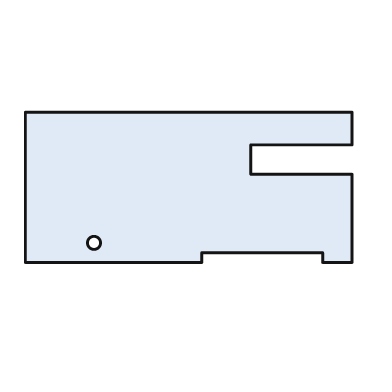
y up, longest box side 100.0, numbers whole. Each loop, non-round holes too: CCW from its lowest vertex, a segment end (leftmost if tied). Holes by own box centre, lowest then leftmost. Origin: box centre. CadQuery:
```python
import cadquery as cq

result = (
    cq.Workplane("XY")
    .moveTo(-50.0, -23.0)
    .lineTo(4.0, -23.0)
    .lineTo(4.0, -20.0)
    .lineTo(41.0, -20.0)
    .lineTo(41.0, -23.0)
    .lineTo(50.0, -23.0)
    .lineTo(50.0, 4.0)
    .lineTo(19.0, 4.0)
    .lineTo(19.0, 13.0)
    .lineTo(50.0, 13.0)
    .lineTo(50.0, 23.0)
    .lineTo(-50.0, 23.0)
    .close()
    .moveTo(-29.0, -17.0)
    .circle(2.0)
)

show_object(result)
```